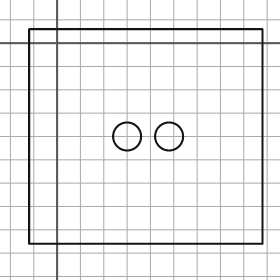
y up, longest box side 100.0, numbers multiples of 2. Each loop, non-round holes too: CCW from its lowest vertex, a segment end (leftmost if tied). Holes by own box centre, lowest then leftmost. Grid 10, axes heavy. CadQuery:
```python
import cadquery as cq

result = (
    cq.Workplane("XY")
    .moveTo(-12.0, -86.0)
    .lineTo(88.0, -86.0)
    .lineTo(88.0, 6.0)
    .lineTo(-12.0, 6.0)
    .close()
    .moveTo(30.0, -40.0)
    .circle(6.0)
    .moveTo(48.0, -40.0)
    .circle(6.0)
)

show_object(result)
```